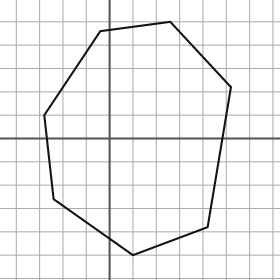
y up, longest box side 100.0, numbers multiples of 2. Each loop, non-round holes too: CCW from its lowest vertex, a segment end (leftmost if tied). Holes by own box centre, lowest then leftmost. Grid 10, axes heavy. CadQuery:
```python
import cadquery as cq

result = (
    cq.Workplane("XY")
    .moveTo(10.0, -50.0)
    .lineTo(42.0, -38.0)
    .lineTo(52.0, 22.0)
    .lineTo(26.0, 50.0)
    .lineTo(-4.0, 46.0)
    .lineTo(-28.0, 10.0)
    .lineTo(-24.0, -26.0)
    .close()
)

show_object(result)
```